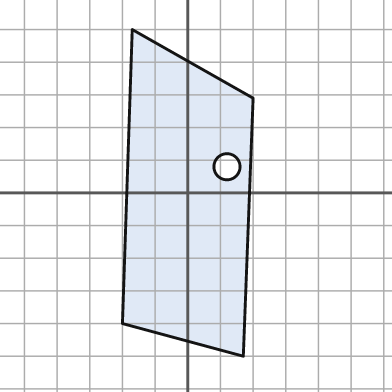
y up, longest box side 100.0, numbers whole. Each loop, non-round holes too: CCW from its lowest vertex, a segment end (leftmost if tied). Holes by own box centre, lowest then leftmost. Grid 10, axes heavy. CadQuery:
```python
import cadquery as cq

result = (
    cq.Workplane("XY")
    .moveTo(17.0, -50.0)
    .lineTo(20.0, 29.0)
    .lineTo(-17.0, 50.0)
    .lineTo(-20.0, -40.0)
    .close()
    .moveTo(12.0, 8.0)
    .circle(4.0)
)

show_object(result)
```